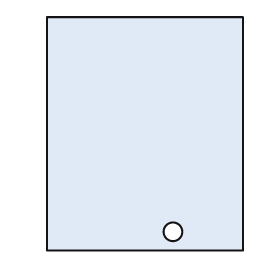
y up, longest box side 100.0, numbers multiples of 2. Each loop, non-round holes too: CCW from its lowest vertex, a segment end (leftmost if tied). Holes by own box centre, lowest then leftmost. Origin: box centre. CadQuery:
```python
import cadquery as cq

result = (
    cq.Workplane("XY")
    .moveTo(-42.0, -50.0)
    .lineTo(42.0, -50.0)
    .lineTo(42.0, 50.0)
    .lineTo(-42.0, 50.0)
    .close()
    .moveTo(12.0, -42.0)
    .circle(4.0)
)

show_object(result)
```